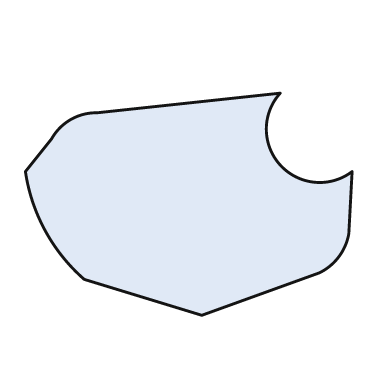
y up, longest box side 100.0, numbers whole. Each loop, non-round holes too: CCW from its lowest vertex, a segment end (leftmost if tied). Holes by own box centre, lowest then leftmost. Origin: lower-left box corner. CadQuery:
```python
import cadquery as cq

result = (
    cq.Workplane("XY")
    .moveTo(54.0, 0.0)
    .lineTo(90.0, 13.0)
    .threePointArc((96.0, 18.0), (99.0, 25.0))
    .lineTo(100.0, 44.0)
    .threePointArc((78.0, 46.0), (78.0, 68.0))
    .lineTo(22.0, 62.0)
    .threePointArc((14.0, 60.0), (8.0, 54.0))
    .lineTo(0.0, 44.0)
    .threePointArc((6.0, 26.0), (18.0, 11.0))
    .close()
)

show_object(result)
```